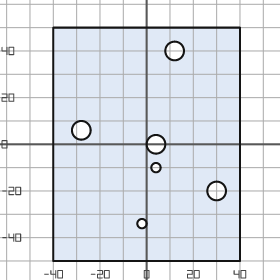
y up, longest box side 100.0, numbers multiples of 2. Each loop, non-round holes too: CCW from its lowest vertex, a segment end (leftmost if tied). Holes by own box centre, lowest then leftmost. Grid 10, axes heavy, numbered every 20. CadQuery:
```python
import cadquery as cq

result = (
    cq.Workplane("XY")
    .moveTo(-40.0, -50.0)
    .lineTo(40.0, -50.0)
    .lineTo(40.0, 50.0)
    .lineTo(-40.0, 50.0)
    .close()
    .moveTo(-2.0, -34.0)
    .circle(2.0)
    .moveTo(30.0, -20.0)
    .circle(4.0)
    .moveTo(4.0, -10.0)
    .circle(2.0)
    .moveTo(4.0, 0.0)
    .circle(4.0)
    .moveTo(-28.0, 6.0)
    .circle(4.0)
    .moveTo(12.0, 40.0)
    .circle(4.0)
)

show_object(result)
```